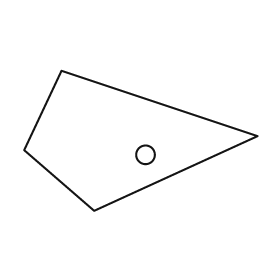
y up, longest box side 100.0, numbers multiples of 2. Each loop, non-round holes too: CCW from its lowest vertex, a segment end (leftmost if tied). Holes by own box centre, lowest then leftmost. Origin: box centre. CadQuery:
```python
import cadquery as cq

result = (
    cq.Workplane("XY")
    .moveTo(-20.0, -30.0)
    .lineTo(50.0, 2.0)
    .lineTo(-34.0, 30.0)
    .lineTo(-50.0, -4.0)
    .close()
    .moveTo(2.0, -6.0)
    .circle(4.0)
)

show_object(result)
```